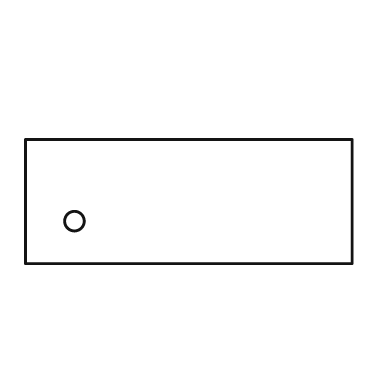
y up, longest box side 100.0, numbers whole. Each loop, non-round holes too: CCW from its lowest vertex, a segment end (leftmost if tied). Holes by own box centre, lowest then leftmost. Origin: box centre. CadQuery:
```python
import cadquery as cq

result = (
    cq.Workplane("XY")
    .moveTo(-50.0, -19.0)
    .lineTo(50.0, -19.0)
    .lineTo(50.0, 19.0)
    .lineTo(-50.0, 19.0)
    .close()
    .moveTo(-35.0, -6.0)
    .circle(3.0)
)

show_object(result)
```